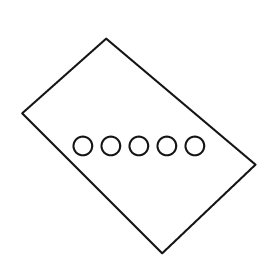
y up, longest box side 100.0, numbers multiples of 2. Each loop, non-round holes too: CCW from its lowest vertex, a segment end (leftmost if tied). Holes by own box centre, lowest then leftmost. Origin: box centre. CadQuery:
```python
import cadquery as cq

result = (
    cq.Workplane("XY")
    .moveTo(10.0, -46.0)
    .lineTo(50.0, -8.0)
    .lineTo(-14.0, 46.0)
    .lineTo(-50.0, 14.0)
    .close()
    .moveTo(-24.0, 0.0)
    .circle(4.0)
    .moveTo(-12.0, 0.0)
    .circle(4.0)
    .moveTo(0.0, 0.0)
    .circle(4.0)
    .moveTo(12.0, 0.0)
    .circle(4.0)
    .moveTo(24.0, 0.0)
    .circle(4.0)
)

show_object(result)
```